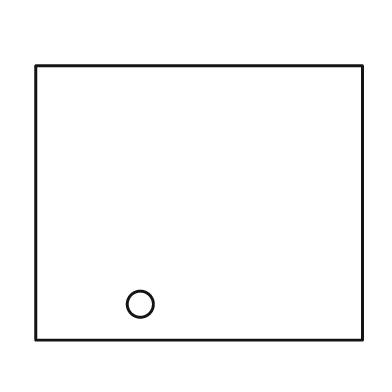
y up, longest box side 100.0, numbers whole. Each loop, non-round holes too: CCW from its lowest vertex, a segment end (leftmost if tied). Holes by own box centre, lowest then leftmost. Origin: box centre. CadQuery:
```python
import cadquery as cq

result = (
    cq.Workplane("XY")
    .moveTo(-50.0, -42.0)
    .lineTo(50.0, -42.0)
    .lineTo(50.0, 42.0)
    .lineTo(-50.0, 42.0)
    .close()
    .moveTo(-18.0, -31.0)
    .circle(4.0)
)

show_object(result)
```